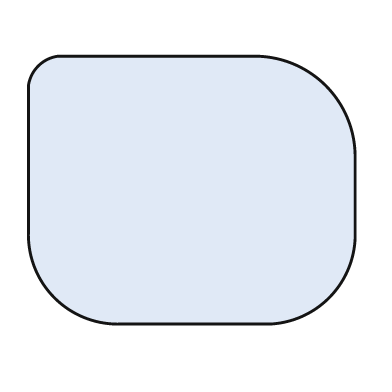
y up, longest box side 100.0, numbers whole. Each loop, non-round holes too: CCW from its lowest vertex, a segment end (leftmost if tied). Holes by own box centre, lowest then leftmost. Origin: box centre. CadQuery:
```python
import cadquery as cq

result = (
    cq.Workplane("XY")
    .moveTo(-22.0, -41.0)
    .lineTo(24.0, -41.0)
    .threePointArc((42.0, -33.0), (50.0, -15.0))
    .lineTo(50.0, 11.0)
    .threePointArc((41.0, 32.0), (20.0, 41.0))
    .lineTo(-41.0, 41.0)
    .threePointArc((-47.0, 38.0), (-50.0, 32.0))
    .lineTo(-50.0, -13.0)
    .threePointArc((-42.0, -33.0), (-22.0, -41.0))
    .close()
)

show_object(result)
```